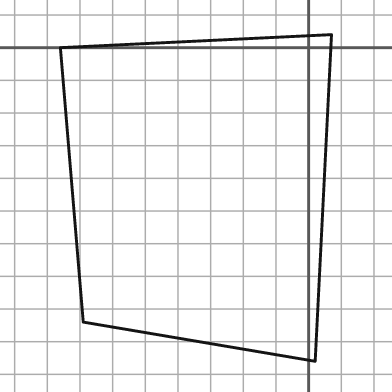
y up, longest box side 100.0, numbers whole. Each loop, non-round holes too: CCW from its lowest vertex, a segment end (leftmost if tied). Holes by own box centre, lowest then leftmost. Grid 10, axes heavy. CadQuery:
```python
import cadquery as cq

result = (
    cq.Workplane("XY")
    .moveTo(2.0, -96.0)
    .lineTo(7.0, 4.0)
    .lineTo(-76.0, 0.0)
    .lineTo(-69.0, -84.0)
    .close()
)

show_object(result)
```